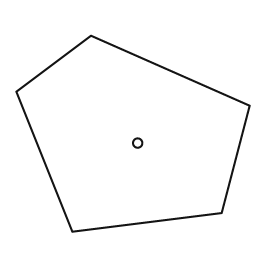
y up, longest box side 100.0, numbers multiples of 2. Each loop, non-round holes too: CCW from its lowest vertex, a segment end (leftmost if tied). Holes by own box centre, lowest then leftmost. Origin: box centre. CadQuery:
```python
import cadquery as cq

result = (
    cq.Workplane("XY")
    .moveTo(-26.0, -42.0)
    .lineTo(38.0, -34.0)
    .lineTo(50.0, 12.0)
    .lineTo(-18.0, 42.0)
    .lineTo(-50.0, 18.0)
    .close()
    .moveTo(2.0, -4.0)
    .circle(2.0)
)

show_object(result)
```